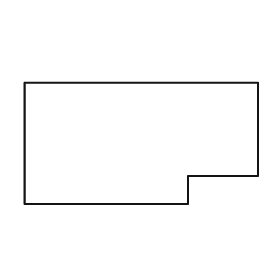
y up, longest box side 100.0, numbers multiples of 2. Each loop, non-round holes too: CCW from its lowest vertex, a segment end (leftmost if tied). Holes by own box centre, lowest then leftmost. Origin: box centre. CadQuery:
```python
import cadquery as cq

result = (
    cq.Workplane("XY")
    .moveTo(-50.0, -26.0)
    .lineTo(20.0, -26.0)
    .lineTo(20.0, -14.0)
    .lineTo(50.0, -14.0)
    .lineTo(50.0, 26.0)
    .lineTo(-50.0, 26.0)
    .close()
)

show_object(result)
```